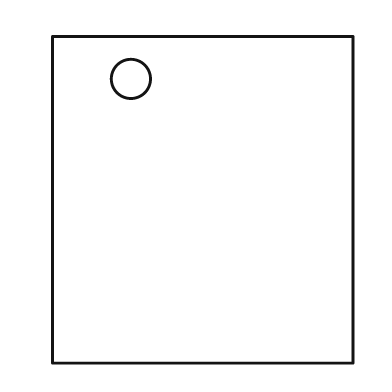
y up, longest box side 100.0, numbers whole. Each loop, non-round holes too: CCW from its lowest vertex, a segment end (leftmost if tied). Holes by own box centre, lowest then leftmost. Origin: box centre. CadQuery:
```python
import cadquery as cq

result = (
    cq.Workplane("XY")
    .moveTo(-46.0, -50.0)
    .lineTo(46.0, -50.0)
    .lineTo(46.0, 50.0)
    .lineTo(-46.0, 50.0)
    .close()
    .moveTo(-22.0, 37.0)
    .circle(6.0)
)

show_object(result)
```